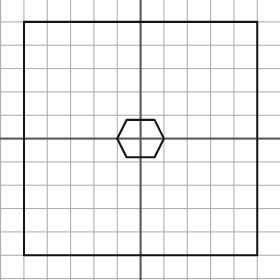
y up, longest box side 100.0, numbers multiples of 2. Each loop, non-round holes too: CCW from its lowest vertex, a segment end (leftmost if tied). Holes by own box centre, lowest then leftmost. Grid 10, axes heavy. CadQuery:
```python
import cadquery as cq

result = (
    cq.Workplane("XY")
    .moveTo(-50.0, -50.0)
    .lineTo(50.0, -50.0)
    .lineTo(50.0, 50.0)
    .lineTo(-50.0, 50.0)
    .close()
    .moveTo(-6.0, -8.0)
    .lineTo(6.0, -8.0)
    .lineTo(10.0, 0.0)
    .lineTo(6.0, 8.0)
    .lineTo(-6.0, 8.0)
    .lineTo(-10.0, 0.0)
    .close()
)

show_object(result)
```